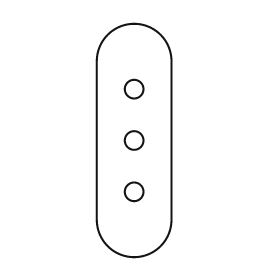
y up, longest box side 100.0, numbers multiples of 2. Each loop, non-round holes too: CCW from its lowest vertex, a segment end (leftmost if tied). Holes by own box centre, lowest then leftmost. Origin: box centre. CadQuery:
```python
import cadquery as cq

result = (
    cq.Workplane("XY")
    .moveTo(-16.0, -34.0)
    .threePointArc((0.0, -50.0), (16.0, -34.0))
    .lineTo(16.0, 34.0)
    .threePointArc((0.0, 50.0), (-16.0, 34.0))
    .close()
    .moveTo(0.0, -22.0)
    .circle(4.0)
    .moveTo(0.0, 0.0)
    .circle(4.0)
    .moveTo(0.0, 22.0)
    .circle(4.0)
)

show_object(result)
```